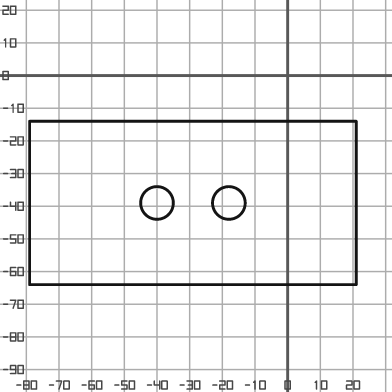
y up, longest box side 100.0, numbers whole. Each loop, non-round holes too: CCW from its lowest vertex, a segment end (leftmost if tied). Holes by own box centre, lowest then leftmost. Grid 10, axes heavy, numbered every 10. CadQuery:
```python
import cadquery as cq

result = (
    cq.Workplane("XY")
    .moveTo(-79.0, -64.0)
    .lineTo(21.0, -64.0)
    .lineTo(21.0, -14.0)
    .lineTo(-79.0, -14.0)
    .close()
    .moveTo(-40.0, -39.0)
    .circle(5.0)
    .moveTo(-18.0, -39.0)
    .circle(5.0)
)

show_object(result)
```